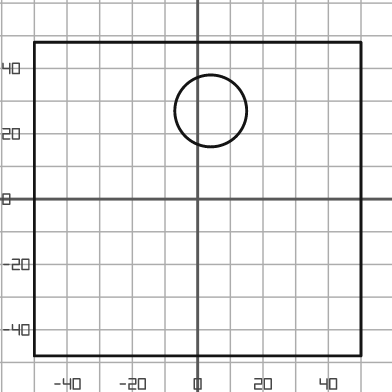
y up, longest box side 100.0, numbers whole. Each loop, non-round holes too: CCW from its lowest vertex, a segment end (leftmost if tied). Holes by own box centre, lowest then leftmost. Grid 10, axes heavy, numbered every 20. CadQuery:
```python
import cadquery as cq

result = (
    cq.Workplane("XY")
    .moveTo(-50.0, -48.0)
    .lineTo(50.0, -48.0)
    .lineTo(50.0, 48.0)
    .lineTo(-50.0, 48.0)
    .close()
    .moveTo(4.0, 27.0)
    .circle(11.0)
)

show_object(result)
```